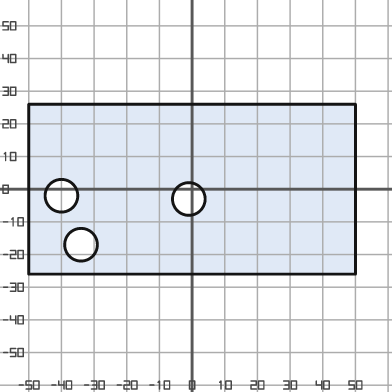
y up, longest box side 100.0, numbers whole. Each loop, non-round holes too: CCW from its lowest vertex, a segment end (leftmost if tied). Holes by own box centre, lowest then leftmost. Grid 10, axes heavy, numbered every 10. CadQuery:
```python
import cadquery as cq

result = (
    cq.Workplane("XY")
    .moveTo(-50.0, -26.0)
    .lineTo(50.0, -26.0)
    .lineTo(50.0, 26.0)
    .lineTo(-50.0, 26.0)
    .close()
    .moveTo(-34.0, -17.0)
    .circle(5.0)
    .moveTo(-1.0, -3.0)
    .circle(5.0)
    .moveTo(-40.0, -2.0)
    .circle(5.0)
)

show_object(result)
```